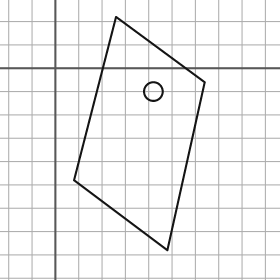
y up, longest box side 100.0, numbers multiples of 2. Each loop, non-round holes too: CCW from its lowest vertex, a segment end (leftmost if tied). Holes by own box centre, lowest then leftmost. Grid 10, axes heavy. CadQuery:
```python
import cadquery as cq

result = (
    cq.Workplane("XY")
    .moveTo(48.0, -78.0)
    .lineTo(64.0, -6.0)
    .lineTo(26.0, 22.0)
    .lineTo(8.0, -48.0)
    .close()
    .moveTo(42.0, -10.0)
    .circle(4.0)
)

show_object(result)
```